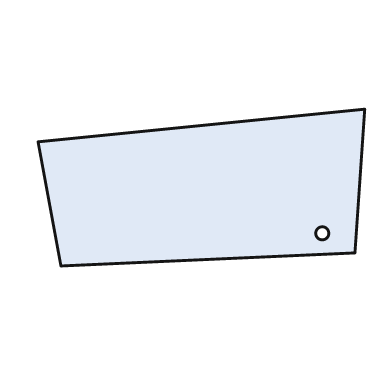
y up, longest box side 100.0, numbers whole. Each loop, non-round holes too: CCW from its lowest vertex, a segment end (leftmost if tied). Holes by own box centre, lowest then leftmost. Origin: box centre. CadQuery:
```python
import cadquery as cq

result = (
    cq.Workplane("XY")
    .moveTo(-43.0, -24.0)
    .lineTo(47.0, -20.0)
    .lineTo(50.0, 24.0)
    .lineTo(-50.0, 14.0)
    .close()
    .moveTo(37.0, -14.0)
    .circle(2.0)
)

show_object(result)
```